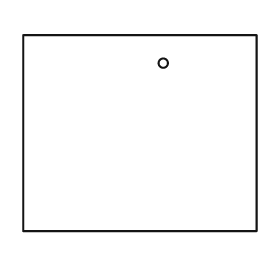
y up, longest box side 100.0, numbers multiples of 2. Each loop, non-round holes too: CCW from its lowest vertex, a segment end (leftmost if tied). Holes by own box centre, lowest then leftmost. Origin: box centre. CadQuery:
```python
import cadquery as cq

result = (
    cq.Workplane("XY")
    .moveTo(-50.0, -42.0)
    .lineTo(50.0, -42.0)
    .lineTo(50.0, 42.0)
    .lineTo(-50.0, 42.0)
    .close()
    .moveTo(10.0, 30.0)
    .circle(2.0)
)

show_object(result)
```